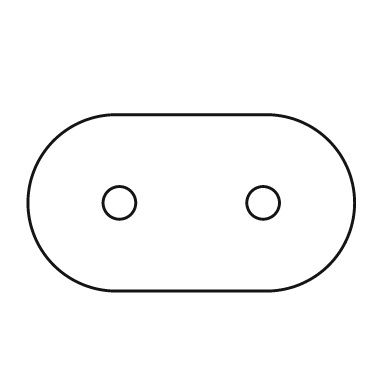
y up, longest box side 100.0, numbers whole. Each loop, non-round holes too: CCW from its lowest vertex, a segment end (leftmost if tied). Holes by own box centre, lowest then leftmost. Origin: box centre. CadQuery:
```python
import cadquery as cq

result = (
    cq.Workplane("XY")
    .moveTo(-23.0, -27.0)
    .lineTo(23.0, -27.0)
    .threePointArc((50.0, 0.0), (23.0, 27.0))
    .lineTo(-23.0, 27.0)
    .threePointArc((-50.0, 0.0), (-23.0, -27.0))
    .close()
    .moveTo(-22.0, 0.0)
    .circle(5.0)
    .moveTo(22.0, 0.0)
    .circle(5.0)
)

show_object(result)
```